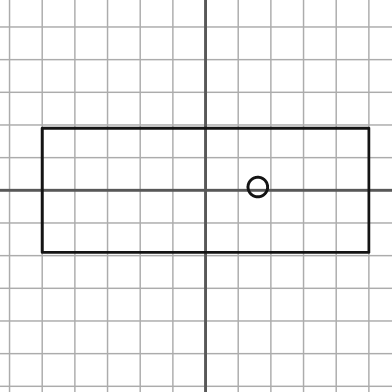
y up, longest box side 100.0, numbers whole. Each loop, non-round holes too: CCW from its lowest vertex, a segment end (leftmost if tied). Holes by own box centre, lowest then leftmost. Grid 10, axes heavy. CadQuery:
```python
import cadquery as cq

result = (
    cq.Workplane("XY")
    .moveTo(-50.0, -19.0)
    .lineTo(50.0, -19.0)
    .lineTo(50.0, 19.0)
    .lineTo(-50.0, 19.0)
    .close()
    .moveTo(16.0, 1.0)
    .circle(3.0)
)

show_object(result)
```